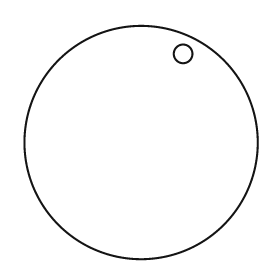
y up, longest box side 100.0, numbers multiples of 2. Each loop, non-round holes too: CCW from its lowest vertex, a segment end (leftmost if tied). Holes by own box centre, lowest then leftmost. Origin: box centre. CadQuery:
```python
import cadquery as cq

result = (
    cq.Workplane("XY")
    .moveTo(0.0, 0.0)
    .circle(50.0)
    .moveTo(18.0, 38.0)
    .circle(4.0)
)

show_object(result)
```